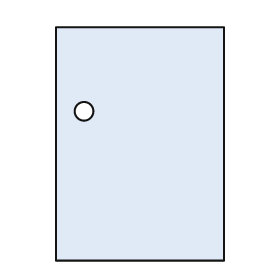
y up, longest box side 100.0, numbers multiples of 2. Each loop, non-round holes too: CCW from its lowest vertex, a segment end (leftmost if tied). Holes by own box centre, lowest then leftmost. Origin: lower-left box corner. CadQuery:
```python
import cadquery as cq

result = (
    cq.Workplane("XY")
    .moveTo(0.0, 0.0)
    .lineTo(72.0, 0.0)
    .lineTo(72.0, 100.0)
    .lineTo(0.0, 100.0)
    .close()
    .moveTo(12.0, 64.0)
    .circle(4.0)
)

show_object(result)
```